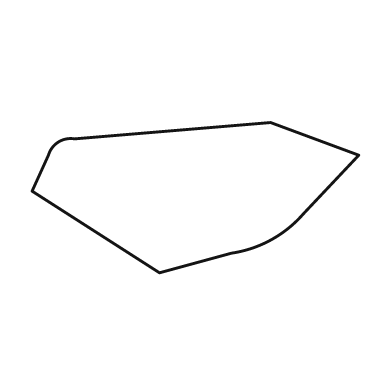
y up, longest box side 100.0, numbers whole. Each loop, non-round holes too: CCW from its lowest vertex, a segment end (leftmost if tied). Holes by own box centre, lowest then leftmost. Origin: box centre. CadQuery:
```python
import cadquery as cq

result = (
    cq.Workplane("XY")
    .moveTo(-11.0, -23.0)
    .lineTo(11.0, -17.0)
    .threePointArc((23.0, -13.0), (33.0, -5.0))
    .lineTo(50.0, 13.0)
    .lineTo(23.0, 23.0)
    .lineTo(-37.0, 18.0)
    .threePointArc((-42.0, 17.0), (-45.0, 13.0))
    .lineTo(-50.0, 2.0)
    .close()
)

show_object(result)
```